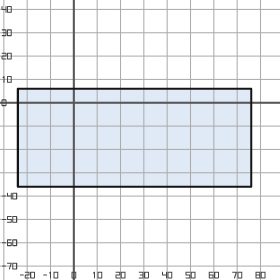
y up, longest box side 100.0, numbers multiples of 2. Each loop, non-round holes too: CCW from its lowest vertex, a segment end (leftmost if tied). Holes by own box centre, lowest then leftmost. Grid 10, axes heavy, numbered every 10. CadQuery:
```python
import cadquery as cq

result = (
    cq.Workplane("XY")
    .moveTo(-24.0, -36.0)
    .lineTo(76.0, -36.0)
    .lineTo(76.0, 6.0)
    .lineTo(-24.0, 6.0)
    .close()
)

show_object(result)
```